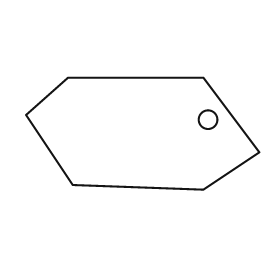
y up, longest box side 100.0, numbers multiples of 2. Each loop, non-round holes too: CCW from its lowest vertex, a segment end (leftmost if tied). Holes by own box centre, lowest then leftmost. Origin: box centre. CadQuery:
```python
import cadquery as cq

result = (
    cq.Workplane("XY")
    .moveTo(26.0, -24.0)
    .lineTo(50.0, -8.0)
    .lineTo(26.0, 24.0)
    .lineTo(-32.0, 24.0)
    .lineTo(-50.0, 8.0)
    .lineTo(-30.0, -22.0)
    .close()
    .moveTo(28.0, 6.0)
    .circle(4.0)
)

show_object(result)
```